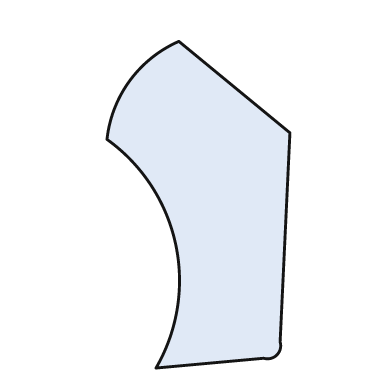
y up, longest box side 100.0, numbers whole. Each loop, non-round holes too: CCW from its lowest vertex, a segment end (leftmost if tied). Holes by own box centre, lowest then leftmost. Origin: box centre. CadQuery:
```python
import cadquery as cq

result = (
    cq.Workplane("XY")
    .moveTo(-13.0, -50.0)
    .lineTo(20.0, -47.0)
    .threePointArc((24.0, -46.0), (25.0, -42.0))
    .lineTo(28.0, 22.0)
    .lineTo(-6.0, 50.0)
    .threePointArc((-21.0, 38.0), (-28.0, 20.0))
    .threePointArc((-7.0, -12.0), (-13.0, -50.0))
    .close()
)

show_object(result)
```